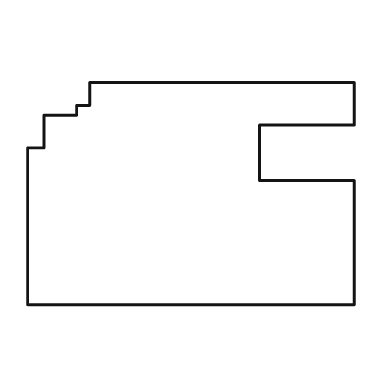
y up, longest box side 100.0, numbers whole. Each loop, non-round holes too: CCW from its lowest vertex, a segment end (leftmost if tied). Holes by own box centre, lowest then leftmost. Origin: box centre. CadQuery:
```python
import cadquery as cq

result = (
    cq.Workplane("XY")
    .moveTo(-50.0, -34.0)
    .lineTo(50.0, -34.0)
    .lineTo(50.0, 4.0)
    .lineTo(21.0, 4.0)
    .lineTo(21.0, 21.0)
    .lineTo(50.0, 21.0)
    .lineTo(50.0, 34.0)
    .lineTo(-31.0, 34.0)
    .lineTo(-31.0, 27.0)
    .lineTo(-35.0, 27.0)
    .lineTo(-35.0, 24.0)
    .lineTo(-45.0, 24.0)
    .lineTo(-45.0, 14.0)
    .lineTo(-50.0, 14.0)
    .close()
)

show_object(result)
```